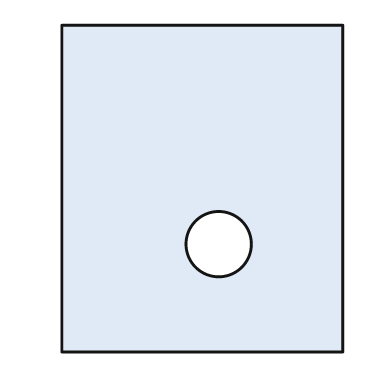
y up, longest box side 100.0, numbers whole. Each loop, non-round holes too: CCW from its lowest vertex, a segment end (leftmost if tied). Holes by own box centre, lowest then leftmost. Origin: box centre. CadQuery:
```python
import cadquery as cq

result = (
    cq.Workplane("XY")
    .moveTo(-43.0, -50.0)
    .lineTo(43.0, -50.0)
    .lineTo(43.0, 50.0)
    .lineTo(-43.0, 50.0)
    .close()
    .moveTo(5.0, -17.0)
    .circle(10.0)
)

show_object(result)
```